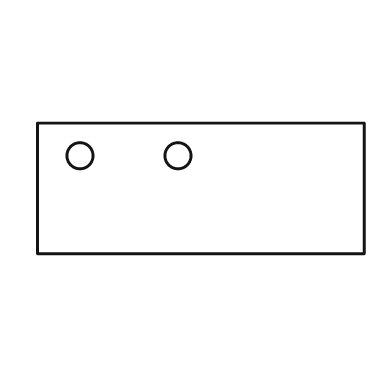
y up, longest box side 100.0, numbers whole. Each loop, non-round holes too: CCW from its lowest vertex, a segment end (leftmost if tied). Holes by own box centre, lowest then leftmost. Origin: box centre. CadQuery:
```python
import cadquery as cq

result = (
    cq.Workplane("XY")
    .moveTo(-50.0, -20.0)
    .lineTo(50.0, -20.0)
    .lineTo(50.0, 20.0)
    .lineTo(-50.0, 20.0)
    .close()
    .moveTo(-37.0, 10.0)
    .circle(4.0)
    .moveTo(-7.0, 10.0)
    .circle(4.0)
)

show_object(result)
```